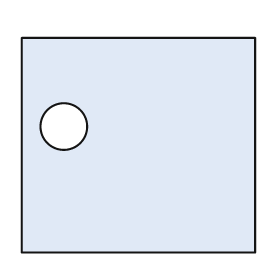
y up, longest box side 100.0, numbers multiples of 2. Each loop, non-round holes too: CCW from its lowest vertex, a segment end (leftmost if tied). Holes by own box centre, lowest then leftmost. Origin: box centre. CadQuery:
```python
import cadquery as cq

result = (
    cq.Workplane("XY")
    .moveTo(-50.0, -46.0)
    .lineTo(50.0, -46.0)
    .lineTo(50.0, 46.0)
    .lineTo(-50.0, 46.0)
    .close()
    .moveTo(-32.0, 8.0)
    .circle(10.0)
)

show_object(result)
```